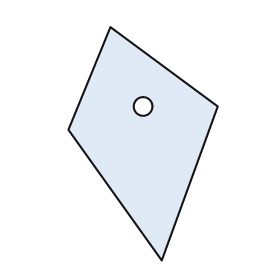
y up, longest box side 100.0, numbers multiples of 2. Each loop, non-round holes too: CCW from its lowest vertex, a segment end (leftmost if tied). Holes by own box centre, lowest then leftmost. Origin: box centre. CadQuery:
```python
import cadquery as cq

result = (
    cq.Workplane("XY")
    .moveTo(8.0, -50.0)
    .lineTo(32.0, 16.0)
    .lineTo(-14.0, 50.0)
    .lineTo(-32.0, 6.0)
    .close()
    .moveTo(0.0, 16.0)
    .circle(4.0)
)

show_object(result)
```